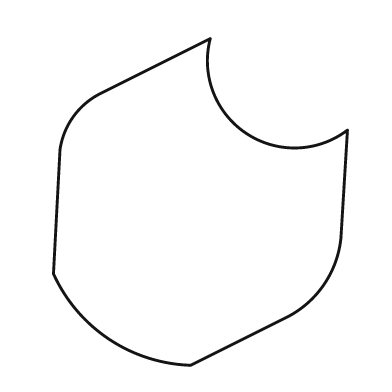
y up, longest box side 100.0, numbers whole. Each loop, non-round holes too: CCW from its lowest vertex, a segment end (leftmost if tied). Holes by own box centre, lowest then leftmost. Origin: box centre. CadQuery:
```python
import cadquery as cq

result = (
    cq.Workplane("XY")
    .moveTo(-3.0, -50.0)
    .lineTo(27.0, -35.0)
    .threePointArc((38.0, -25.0), (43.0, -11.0))
    .lineTo(45.0, 22.0)
    .threePointArc((14.0, 21.0), (3.0, 50.0))
    .lineTo(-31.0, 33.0)
    .threePointArc((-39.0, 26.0), (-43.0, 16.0))
    .lineTo(-45.0, -22.0)
    .threePointArc((-28.0, -42.0), (-3.0, -50.0))
    .close()
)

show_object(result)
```